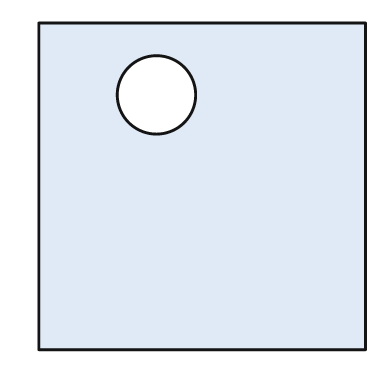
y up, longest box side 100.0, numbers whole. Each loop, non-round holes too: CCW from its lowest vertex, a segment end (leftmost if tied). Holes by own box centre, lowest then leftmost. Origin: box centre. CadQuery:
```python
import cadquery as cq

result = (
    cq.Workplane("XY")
    .moveTo(-50.0, -50.0)
    .lineTo(50.0, -50.0)
    .lineTo(50.0, 50.0)
    .lineTo(-50.0, 50.0)
    .close()
    .moveTo(-14.0, 28.0)
    .circle(12.0)
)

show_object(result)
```